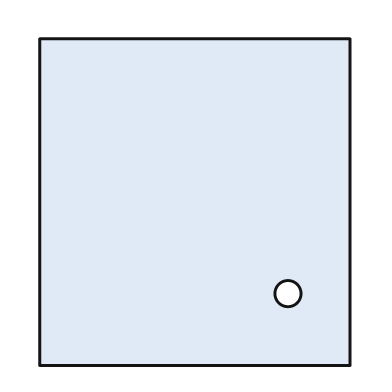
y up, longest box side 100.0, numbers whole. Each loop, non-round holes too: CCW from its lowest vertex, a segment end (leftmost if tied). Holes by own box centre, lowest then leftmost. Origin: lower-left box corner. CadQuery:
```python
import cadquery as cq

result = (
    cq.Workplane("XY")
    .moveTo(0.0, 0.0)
    .lineTo(95.0, 0.0)
    .lineTo(95.0, 100.0)
    .lineTo(0.0, 100.0)
    .close()
    .moveTo(76.0, 22.0)
    .circle(4.0)
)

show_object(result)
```